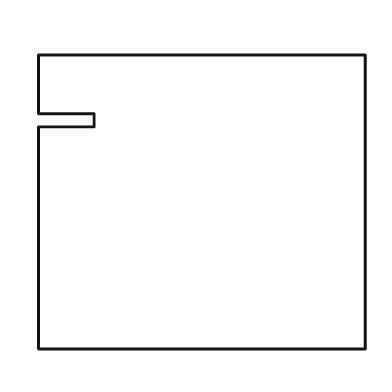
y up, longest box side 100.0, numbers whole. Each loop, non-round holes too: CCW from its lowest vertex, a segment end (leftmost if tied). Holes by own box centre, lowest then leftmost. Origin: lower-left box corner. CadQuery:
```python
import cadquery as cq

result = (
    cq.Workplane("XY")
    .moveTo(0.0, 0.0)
    .lineTo(100.0, 0.0)
    .lineTo(100.0, 90.0)
    .lineTo(0.0, 90.0)
    .lineTo(0.0, 72.0)
    .lineTo(17.0, 72.0)
    .lineTo(17.0, 68.0)
    .lineTo(0.0, 68.0)
    .close()
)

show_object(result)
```